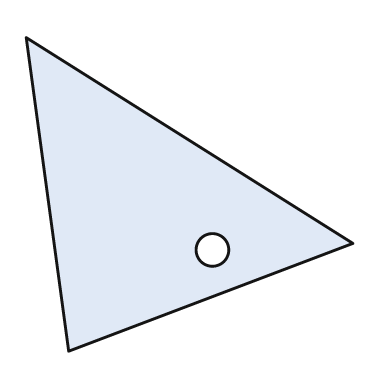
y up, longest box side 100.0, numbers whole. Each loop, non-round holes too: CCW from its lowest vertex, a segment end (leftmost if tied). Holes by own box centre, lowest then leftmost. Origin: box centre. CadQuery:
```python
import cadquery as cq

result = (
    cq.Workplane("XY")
    .moveTo(-37.0, -48.0)
    .lineTo(50.0, -15.0)
    .lineTo(-50.0, 48.0)
    .close()
    .moveTo(7.0, -17.0)
    .circle(5.0)
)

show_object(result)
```